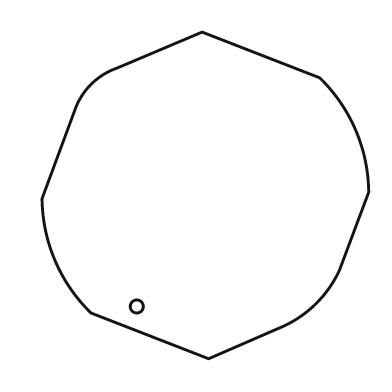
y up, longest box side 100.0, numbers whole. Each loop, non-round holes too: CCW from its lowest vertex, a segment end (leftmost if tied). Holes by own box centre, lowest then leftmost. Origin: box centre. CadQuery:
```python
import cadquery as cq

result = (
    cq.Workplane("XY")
    .moveTo(1.0, -50.0)
    .lineTo(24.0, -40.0)
    .threePointArc((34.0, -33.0), (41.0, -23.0))
    .lineTo(50.0, 1.0)
    .threePointArc((46.0, 20.0), (35.0, 36.0))
    .lineTo(-1.0, 50.0)
    .lineTo(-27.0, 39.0)
    .threePointArc((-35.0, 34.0), (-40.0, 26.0))
    .lineTo(-50.0, -1.0)
    .threePointArc((-46.0, -20.0), (-35.0, -36.0))
    .close()
    .moveTo(-21.0, -34.0)
    .circle(2.0)
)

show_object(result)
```